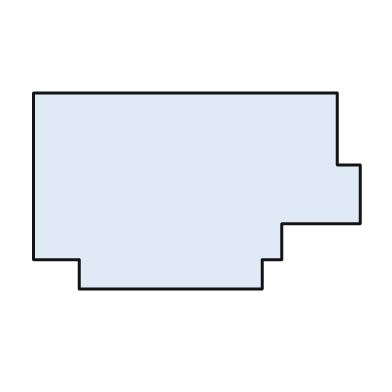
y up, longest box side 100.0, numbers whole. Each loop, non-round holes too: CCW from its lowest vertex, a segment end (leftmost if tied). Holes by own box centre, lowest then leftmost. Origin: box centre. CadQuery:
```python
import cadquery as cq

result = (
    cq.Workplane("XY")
    .moveTo(-36.0, -30.0)
    .lineTo(20.0, -30.0)
    .lineTo(20.0, -21.0)
    .lineTo(26.0, -21.0)
    .lineTo(26.0, -10.0)
    .lineTo(50.0, -10.0)
    .lineTo(50.0, 8.0)
    .lineTo(43.0, 8.0)
    .lineTo(43.0, 30.0)
    .lineTo(-50.0, 30.0)
    .lineTo(-50.0, -21.0)
    .lineTo(-36.0, -21.0)
    .close()
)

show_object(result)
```